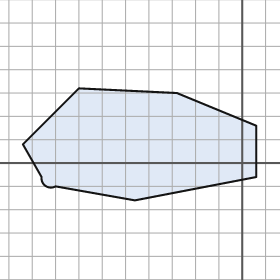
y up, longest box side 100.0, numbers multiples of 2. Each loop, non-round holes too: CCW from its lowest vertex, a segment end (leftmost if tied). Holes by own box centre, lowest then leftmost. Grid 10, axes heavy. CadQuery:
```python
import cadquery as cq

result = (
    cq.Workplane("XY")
    .moveTo(-46.0, -16.0)
    .lineTo(6.0, -6.0)
    .lineTo(6.0, 16.0)
    .lineTo(-28.0, 30.0)
    .lineTo(-70.0, 32.0)
    .lineTo(-94.0, 8.0)
    .lineTo(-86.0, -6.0)
    .threePointArc((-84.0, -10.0), (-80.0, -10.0))
    .close()
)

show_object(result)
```